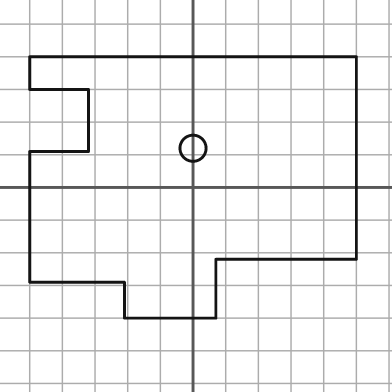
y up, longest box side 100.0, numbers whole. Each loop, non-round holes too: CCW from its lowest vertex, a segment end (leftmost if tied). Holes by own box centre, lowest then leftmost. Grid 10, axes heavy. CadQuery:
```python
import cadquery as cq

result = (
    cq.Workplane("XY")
    .moveTo(-21.0, -40.0)
    .lineTo(7.0, -40.0)
    .lineTo(7.0, -22.0)
    .lineTo(50.0, -22.0)
    .lineTo(50.0, 40.0)
    .lineTo(-50.0, 40.0)
    .lineTo(-50.0, 30.0)
    .lineTo(-32.0, 30.0)
    .lineTo(-32.0, 11.0)
    .lineTo(-50.0, 11.0)
    .lineTo(-50.0, -29.0)
    .lineTo(-21.0, -29.0)
    .close()
    .moveTo(0.0, 12.0)
    .circle(4.0)
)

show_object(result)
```